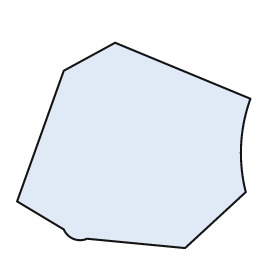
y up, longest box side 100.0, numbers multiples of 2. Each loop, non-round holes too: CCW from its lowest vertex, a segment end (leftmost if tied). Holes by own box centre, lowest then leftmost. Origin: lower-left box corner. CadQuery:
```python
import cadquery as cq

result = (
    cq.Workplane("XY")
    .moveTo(72.0, 0.0)
    .lineTo(98.0, 24.0)
    .threePointArc((96.0, 44.0), (100.0, 64.0))
    .lineTo(42.0, 88.0)
    .lineTo(20.0, 76.0)
    .lineTo(0.0, 20.0)
    .lineTo(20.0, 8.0)
    .threePointArc((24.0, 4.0), (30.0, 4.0))
    .close()
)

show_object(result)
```